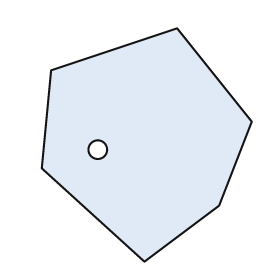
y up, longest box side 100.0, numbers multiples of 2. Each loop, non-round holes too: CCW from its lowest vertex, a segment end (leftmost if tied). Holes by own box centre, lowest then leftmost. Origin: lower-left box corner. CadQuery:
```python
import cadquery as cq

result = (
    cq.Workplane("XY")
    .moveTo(44.0, 0.0)
    .lineTo(76.0, 24.0)
    .lineTo(90.0, 60.0)
    .lineTo(58.0, 100.0)
    .lineTo(4.0, 82.0)
    .lineTo(0.0, 40.0)
    .close()
    .moveTo(24.0, 48.0)
    .circle(4.0)
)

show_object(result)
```